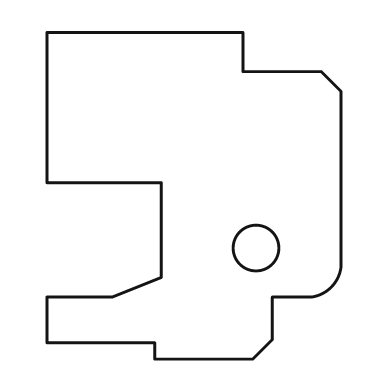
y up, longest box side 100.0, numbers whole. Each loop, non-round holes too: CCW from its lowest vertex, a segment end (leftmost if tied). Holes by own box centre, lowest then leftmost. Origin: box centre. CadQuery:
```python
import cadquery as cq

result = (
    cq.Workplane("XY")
    .moveTo(-12.0, -50.0)
    .lineTo(18.0, -50.0)
    .lineTo(24.0, -44.0)
    .lineTo(24.0, -31.0)
    .lineTo(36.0, -31.0)
    .threePointArc((42.0, -28.0), (45.0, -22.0))
    .lineTo(45.0, 32.0)
    .lineTo(39.0, 38.0)
    .lineTo(15.0, 38.0)
    .lineTo(15.0, 50.0)
    .lineTo(-45.0, 50.0)
    .lineTo(-45.0, 4.0)
    .lineTo(-10.0, 4.0)
    .lineTo(-10.0, -25.0)
    .lineTo(-25.0, -31.0)
    .lineTo(-45.0, -31.0)
    .lineTo(-45.0, -45.0)
    .lineTo(-12.0, -45.0)
    .close()
    .moveTo(19.0, -16.0)
    .circle(7.0)
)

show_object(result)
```